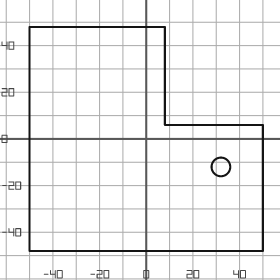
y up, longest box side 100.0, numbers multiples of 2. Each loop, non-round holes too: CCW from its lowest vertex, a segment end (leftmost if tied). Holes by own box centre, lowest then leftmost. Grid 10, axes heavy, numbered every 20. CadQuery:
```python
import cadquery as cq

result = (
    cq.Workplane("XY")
    .moveTo(-50.0, -48.0)
    .lineTo(50.0, -48.0)
    .lineTo(50.0, 6.0)
    .lineTo(8.0, 6.0)
    .lineTo(8.0, 48.0)
    .lineTo(-50.0, 48.0)
    .close()
    .moveTo(32.0, -12.0)
    .circle(4.0)
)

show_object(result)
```